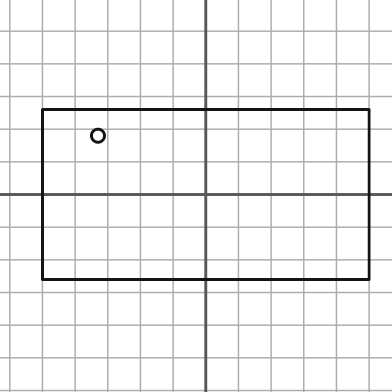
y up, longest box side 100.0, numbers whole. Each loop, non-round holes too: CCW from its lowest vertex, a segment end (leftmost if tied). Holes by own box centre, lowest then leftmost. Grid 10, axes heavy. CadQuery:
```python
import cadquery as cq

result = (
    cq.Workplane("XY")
    .moveTo(-50.0, -26.0)
    .lineTo(50.0, -26.0)
    .lineTo(50.0, 26.0)
    .lineTo(-50.0, 26.0)
    .close()
    .moveTo(-33.0, 18.0)
    .circle(2.0)
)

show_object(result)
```